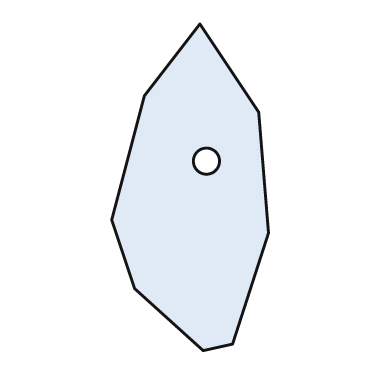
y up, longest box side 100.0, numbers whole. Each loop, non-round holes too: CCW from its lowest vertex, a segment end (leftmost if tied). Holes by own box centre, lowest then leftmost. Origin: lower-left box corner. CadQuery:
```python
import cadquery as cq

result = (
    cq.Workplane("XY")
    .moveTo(28.0, 0.0)
    .lineTo(37.0, 2.0)
    .lineTo(48.0, 36.0)
    .lineTo(45.0, 73.0)
    .lineTo(27.0, 100.0)
    .lineTo(10.0, 78.0)
    .lineTo(0.0, 40.0)
    .lineTo(7.0, 19.0)
    .close()
    .moveTo(29.0, 58.0)
    .circle(4.0)
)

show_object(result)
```